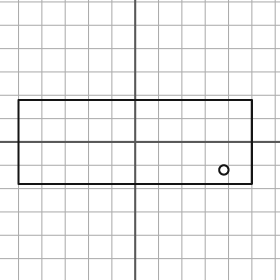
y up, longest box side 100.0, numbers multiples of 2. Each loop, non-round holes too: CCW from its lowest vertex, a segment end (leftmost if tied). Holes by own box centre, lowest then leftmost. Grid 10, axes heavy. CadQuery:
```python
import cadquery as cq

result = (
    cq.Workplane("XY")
    .moveTo(-50.0, -18.0)
    .lineTo(50.0, -18.0)
    .lineTo(50.0, 18.0)
    .lineTo(-50.0, 18.0)
    .close()
    .moveTo(38.0, -12.0)
    .circle(2.0)
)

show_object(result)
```